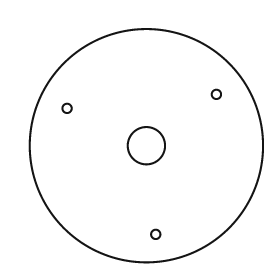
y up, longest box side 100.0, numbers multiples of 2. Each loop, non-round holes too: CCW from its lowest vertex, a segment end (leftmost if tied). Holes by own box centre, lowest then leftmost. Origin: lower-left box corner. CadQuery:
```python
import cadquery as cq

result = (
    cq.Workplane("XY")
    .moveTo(50.0, 50.0)
    .circle(50.0)
    .moveTo(54.0, 12.0)
    .circle(2.0)
    .moveTo(50.0, 50.0)
    .circle(8.0)
    .moveTo(16.0, 66.0)
    .circle(2.0)
    .moveTo(80.0, 72.0)
    .circle(2.0)
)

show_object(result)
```